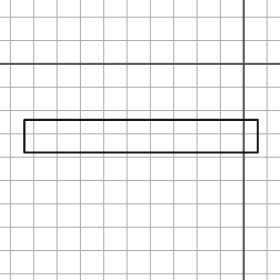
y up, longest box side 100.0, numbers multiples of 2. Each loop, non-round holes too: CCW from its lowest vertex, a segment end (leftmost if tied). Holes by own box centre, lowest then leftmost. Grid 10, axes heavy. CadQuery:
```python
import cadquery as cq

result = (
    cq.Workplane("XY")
    .moveTo(-94.0, -38.0)
    .lineTo(6.0, -38.0)
    .lineTo(6.0, -24.0)
    .lineTo(-94.0, -24.0)
    .close()
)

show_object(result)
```